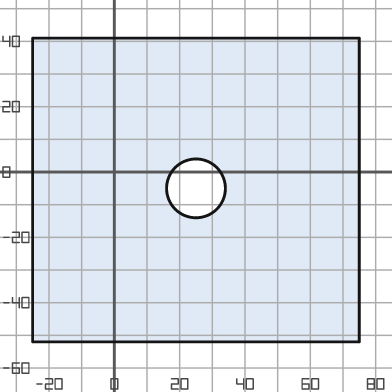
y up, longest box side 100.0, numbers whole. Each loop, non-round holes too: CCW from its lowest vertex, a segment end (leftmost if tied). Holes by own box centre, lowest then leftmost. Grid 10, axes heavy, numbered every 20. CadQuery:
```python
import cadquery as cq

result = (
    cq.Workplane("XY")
    .moveTo(-25.0, -52.0)
    .lineTo(75.0, -52.0)
    .lineTo(75.0, 41.0)
    .lineTo(-25.0, 41.0)
    .close()
    .moveTo(25.0, -5.0)
    .circle(9.0)
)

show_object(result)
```